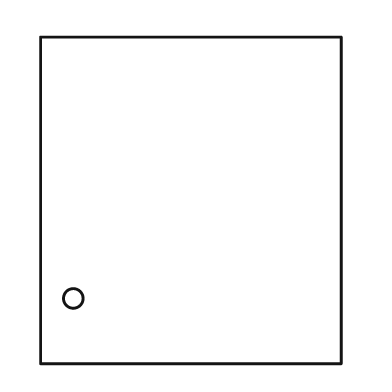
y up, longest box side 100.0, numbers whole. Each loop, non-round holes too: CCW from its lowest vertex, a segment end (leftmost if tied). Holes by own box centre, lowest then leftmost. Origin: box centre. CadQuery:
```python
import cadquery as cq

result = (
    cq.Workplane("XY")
    .moveTo(-46.0, -50.0)
    .lineTo(46.0, -50.0)
    .lineTo(46.0, 50.0)
    .lineTo(-46.0, 50.0)
    .close()
    .moveTo(-36.0, -30.0)
    .circle(3.0)
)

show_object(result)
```